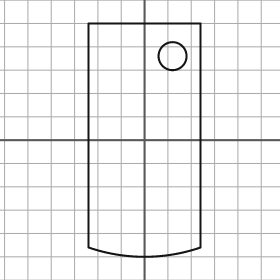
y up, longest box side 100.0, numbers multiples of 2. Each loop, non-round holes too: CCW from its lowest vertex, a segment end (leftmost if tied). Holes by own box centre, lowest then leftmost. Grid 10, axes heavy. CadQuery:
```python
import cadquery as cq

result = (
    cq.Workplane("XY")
    .moveTo(-24.0, -46.0)
    .threePointArc((0.0, -50.0), (24.0, -46.0))
    .lineTo(24.0, 50.0)
    .lineTo(-24.0, 50.0)
    .close()
    .moveTo(12.0, 36.0)
    .circle(6.0)
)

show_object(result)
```